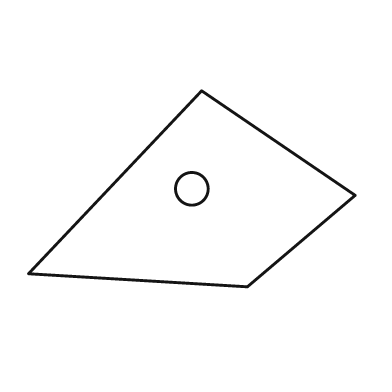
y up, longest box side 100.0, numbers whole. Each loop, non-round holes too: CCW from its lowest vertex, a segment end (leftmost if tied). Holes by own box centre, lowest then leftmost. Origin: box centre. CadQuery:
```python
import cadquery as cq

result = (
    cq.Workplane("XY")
    .moveTo(17.0, -30.0)
    .lineTo(50.0, -2.0)
    .lineTo(3.0, 30.0)
    .lineTo(-50.0, -26.0)
    .close()
    .moveTo(0.0, 0.0)
    .circle(5.0)
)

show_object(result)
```